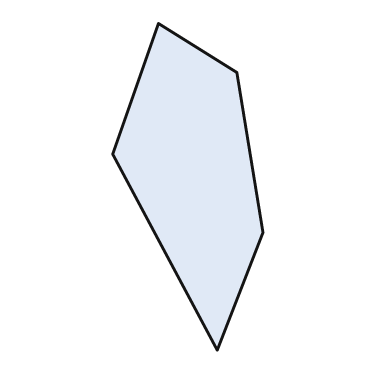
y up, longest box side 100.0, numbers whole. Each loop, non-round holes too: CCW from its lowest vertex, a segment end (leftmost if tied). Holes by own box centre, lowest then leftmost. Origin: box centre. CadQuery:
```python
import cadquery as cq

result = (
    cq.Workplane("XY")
    .moveTo(9.0, -50.0)
    .lineTo(23.0, -14.0)
    .lineTo(15.0, 35.0)
    .lineTo(-9.0, 50.0)
    .lineTo(-23.0, 10.0)
    .close()
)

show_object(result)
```